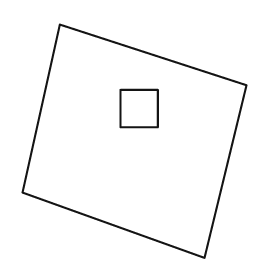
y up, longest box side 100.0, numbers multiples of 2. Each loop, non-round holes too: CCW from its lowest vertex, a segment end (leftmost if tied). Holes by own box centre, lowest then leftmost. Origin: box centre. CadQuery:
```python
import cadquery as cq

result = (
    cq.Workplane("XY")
    .moveTo(30.0, -50.0)
    .lineTo(48.0, 24.0)
    .lineTo(-32.0, 50.0)
    .lineTo(-48.0, -22.0)
    .close()
    .moveTo(-6.0, 6.0)
    .lineTo(10.0, 6.0)
    .lineTo(10.0, 22.0)
    .lineTo(-6.0, 22.0)
    .close()
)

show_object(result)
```